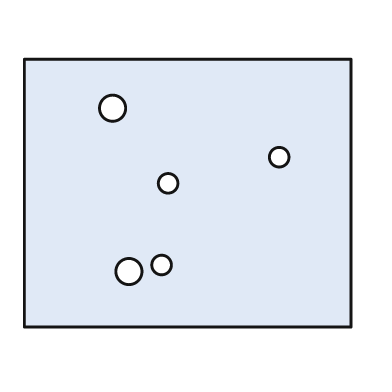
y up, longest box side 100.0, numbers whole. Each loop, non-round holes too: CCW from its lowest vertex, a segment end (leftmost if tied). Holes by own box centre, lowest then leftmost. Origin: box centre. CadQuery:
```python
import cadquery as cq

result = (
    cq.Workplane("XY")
    .moveTo(-50.0, -41.0)
    .lineTo(50.0, -41.0)
    .lineTo(50.0, 41.0)
    .lineTo(-50.0, 41.0)
    .close()
    .moveTo(-18.0, -24.0)
    .circle(4.0)
    .moveTo(-8.0, -22.0)
    .circle(3.0)
    .moveTo(-6.0, 3.0)
    .circle(3.0)
    .moveTo(28.0, 11.0)
    .circle(3.0)
    .moveTo(-23.0, 26.0)
    .circle(4.0)
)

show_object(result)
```